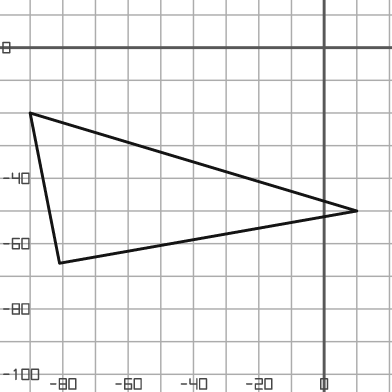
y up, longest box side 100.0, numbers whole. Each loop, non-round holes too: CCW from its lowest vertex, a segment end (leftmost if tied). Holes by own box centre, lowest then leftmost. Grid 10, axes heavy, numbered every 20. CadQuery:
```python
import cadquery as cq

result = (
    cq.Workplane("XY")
    .moveTo(-81.0, -66.0)
    .lineTo(10.0, -50.0)
    .lineTo(-90.0, -20.0)
    .close()
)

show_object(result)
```